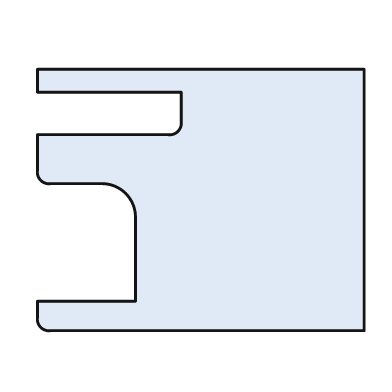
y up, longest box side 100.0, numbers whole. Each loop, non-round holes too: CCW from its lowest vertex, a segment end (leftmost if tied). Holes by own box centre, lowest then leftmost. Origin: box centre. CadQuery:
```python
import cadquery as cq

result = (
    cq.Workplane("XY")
    .moveTo(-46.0, -40.0)
    .lineTo(50.0, -40.0)
    .lineTo(50.0, 40.0)
    .lineTo(-50.0, 40.0)
    .lineTo(-50.0, 33.0)
    .lineTo(-6.0, 33.0)
    .lineTo(-6.0, 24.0)
    .threePointArc((-7.0, 21.0), (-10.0, 20.0))
    .lineTo(-50.0, 20.0)
    .lineTo(-50.0, 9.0)
    .threePointArc((-49.0, 6.0), (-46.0, 5.0))
    .lineTo(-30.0, 5.0)
    .threePointArc((-23.0, 2.0), (-20.0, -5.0))
    .lineTo(-20.0, -31.0)
    .lineTo(-50.0, -31.0)
    .lineTo(-50.0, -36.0)
    .threePointArc((-49.0, -39.0), (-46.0, -40.0))
    .close()
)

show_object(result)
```